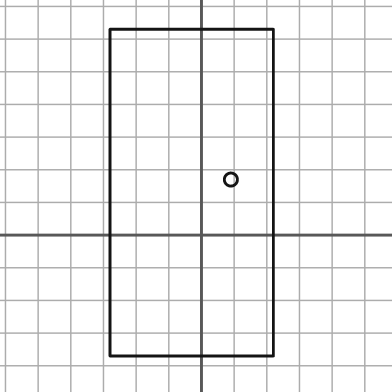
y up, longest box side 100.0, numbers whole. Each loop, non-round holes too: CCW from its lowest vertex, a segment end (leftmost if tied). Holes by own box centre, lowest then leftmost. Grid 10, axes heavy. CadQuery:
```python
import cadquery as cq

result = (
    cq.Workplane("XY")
    .moveTo(-28.0, -37.0)
    .lineTo(22.0, -37.0)
    .lineTo(22.0, 63.0)
    .lineTo(-28.0, 63.0)
    .close()
    .moveTo(9.0, 17.0)
    .circle(2.0)
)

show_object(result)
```